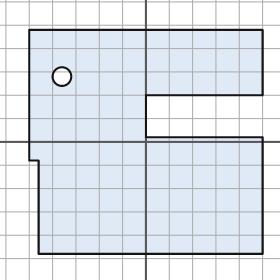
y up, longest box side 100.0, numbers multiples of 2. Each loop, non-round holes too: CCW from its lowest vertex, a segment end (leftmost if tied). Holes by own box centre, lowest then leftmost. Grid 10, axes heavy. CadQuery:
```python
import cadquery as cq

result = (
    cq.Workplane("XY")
    .moveTo(-46.0, -48.0)
    .lineTo(50.0, -48.0)
    .lineTo(50.0, 2.0)
    .lineTo(0.0, 2.0)
    .lineTo(0.0, 20.0)
    .lineTo(50.0, 20.0)
    .lineTo(50.0, 48.0)
    .lineTo(-50.0, 48.0)
    .lineTo(-50.0, -8.0)
    .lineTo(-46.0, -8.0)
    .close()
    .moveTo(-36.0, 28.0)
    .circle(4.0)
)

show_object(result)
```